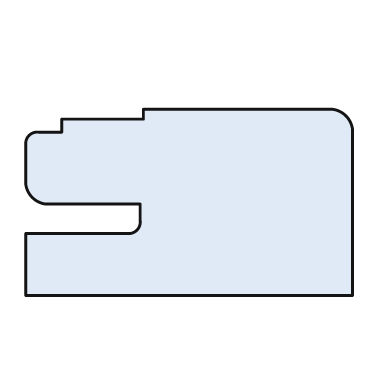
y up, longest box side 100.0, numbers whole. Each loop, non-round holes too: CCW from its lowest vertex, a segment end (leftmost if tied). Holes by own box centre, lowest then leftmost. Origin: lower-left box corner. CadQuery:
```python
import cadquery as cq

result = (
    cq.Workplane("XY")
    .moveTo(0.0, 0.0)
    .lineTo(100.0, 0.0)
    .lineTo(100.0, 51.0)
    .threePointArc((98.0, 55.0), (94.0, 57.0))
    .lineTo(36.0, 57.0)
    .lineTo(36.0, 54.0)
    .lineTo(11.0, 54.0)
    .lineTo(11.0, 50.0)
    .lineTo(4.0, 50.0)
    .threePointArc((1.0, 49.0), (0.0, 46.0))
    .lineTo(0.0, 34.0)
    .threePointArc((2.0, 30.0), (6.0, 28.0))
    .lineTo(35.0, 28.0)
    .lineTo(35.0, 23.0)
    .threePointArc((34.0, 20.0), (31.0, 19.0))
    .lineTo(0.0, 19.0)
    .close()
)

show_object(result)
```